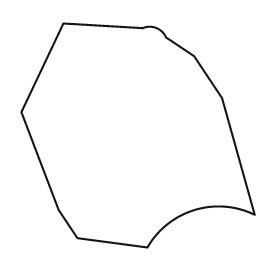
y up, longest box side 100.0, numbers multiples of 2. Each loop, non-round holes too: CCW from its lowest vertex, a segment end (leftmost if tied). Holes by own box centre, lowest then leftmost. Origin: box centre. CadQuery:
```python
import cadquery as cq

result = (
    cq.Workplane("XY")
    .moveTo(4.0, -48.0)
    .threePointArc((24.0, -32.0), (50.0, -34.0))
    .lineTo(36.0, 16.0)
    .lineTo(24.0, 34.0)
    .lineTo(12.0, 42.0)
    .threePointArc((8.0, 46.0), (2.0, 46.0))
    .lineTo(-32.0, 48.0)
    .lineTo(-50.0, 10.0)
    .lineTo(-34.0, -32.0)
    .lineTo(-26.0, -44.0)
    .close()
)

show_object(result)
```